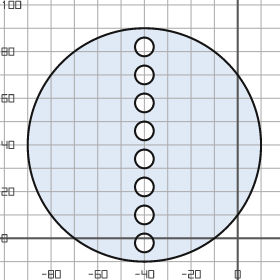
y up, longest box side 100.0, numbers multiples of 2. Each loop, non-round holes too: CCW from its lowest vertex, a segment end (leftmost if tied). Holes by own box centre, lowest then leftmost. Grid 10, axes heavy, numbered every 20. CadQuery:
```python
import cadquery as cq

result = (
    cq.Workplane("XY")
    .moveTo(-40.0, 40.0)
    .circle(50.0)
    .moveTo(-40.0, -2.0)
    .circle(4.0)
    .moveTo(-40.0, 10.0)
    .circle(4.0)
    .moveTo(-40.0, 22.0)
    .circle(4.0)
    .moveTo(-40.0, 34.0)
    .circle(4.0)
    .moveTo(-40.0, 46.0)
    .circle(4.0)
    .moveTo(-40.0, 58.0)
    .circle(4.0)
    .moveTo(-40.0, 70.0)
    .circle(4.0)
    .moveTo(-40.0, 82.0)
    .circle(4.0)
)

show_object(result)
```